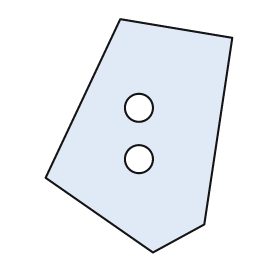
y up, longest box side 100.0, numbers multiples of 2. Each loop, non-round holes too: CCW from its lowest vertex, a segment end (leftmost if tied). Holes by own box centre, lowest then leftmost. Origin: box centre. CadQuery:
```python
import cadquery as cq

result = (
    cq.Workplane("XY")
    .moveTo(6.0, -50.0)
    .lineTo(28.0, -38.0)
    .lineTo(40.0, 42.0)
    .lineTo(-8.0, 50.0)
    .lineTo(-40.0, -18.0)
    .close()
    .moveTo(0.0, -10.0)
    .circle(6.0)
    .moveTo(0.0, 12.0)
    .circle(6.0)
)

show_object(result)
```